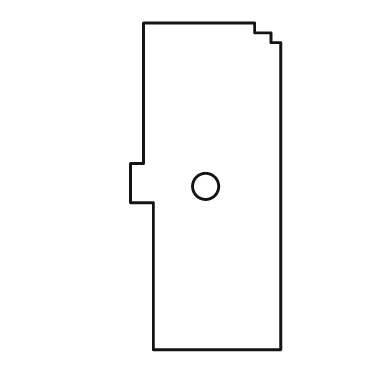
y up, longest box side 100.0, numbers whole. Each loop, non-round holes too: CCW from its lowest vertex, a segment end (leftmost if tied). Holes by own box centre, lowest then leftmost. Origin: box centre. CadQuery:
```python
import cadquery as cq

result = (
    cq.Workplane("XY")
    .moveTo(-16.0, -50.0)
    .lineTo(23.0, -50.0)
    .lineTo(23.0, 44.0)
    .lineTo(20.0, 44.0)
    .lineTo(20.0, 47.0)
    .lineTo(15.0, 47.0)
    .lineTo(15.0, 50.0)
    .lineTo(-19.0, 50.0)
    .lineTo(-19.0, 7.0)
    .lineTo(-23.0, 7.0)
    .lineTo(-23.0, -5.0)
    .lineTo(-16.0, -5.0)
    .close()
    .moveTo(0.0, 0.0)
    .circle(4.0)
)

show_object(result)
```